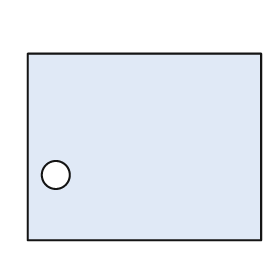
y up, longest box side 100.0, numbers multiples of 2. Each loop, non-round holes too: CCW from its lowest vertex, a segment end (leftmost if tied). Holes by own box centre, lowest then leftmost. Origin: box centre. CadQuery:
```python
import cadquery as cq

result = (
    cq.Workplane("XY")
    .moveTo(-50.0, -40.0)
    .lineTo(50.0, -40.0)
    .lineTo(50.0, 40.0)
    .lineTo(-50.0, 40.0)
    .close()
    .moveTo(-38.0, -12.0)
    .circle(6.0)
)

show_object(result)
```